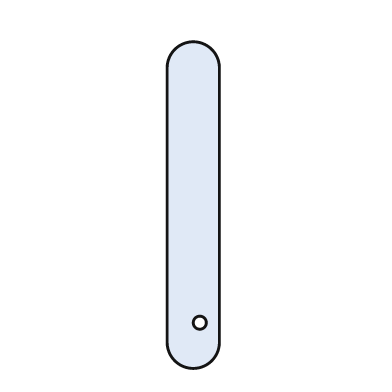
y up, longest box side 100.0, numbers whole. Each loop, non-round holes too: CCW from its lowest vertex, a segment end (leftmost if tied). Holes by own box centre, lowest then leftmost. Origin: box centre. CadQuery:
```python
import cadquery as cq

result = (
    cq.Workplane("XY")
    .moveTo(-8.0, -42.0)
    .threePointArc((0.0, -50.0), (8.0, -42.0))
    .lineTo(8.0, 42.0)
    .threePointArc((0.0, 50.0), (-8.0, 42.0))
    .close()
    .moveTo(2.0, -36.0)
    .circle(2.0)
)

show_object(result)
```